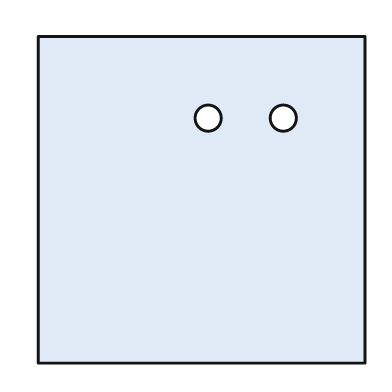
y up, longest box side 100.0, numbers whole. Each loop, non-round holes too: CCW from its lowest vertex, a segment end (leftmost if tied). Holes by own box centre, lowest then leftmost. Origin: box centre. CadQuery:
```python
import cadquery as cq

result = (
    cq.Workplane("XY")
    .moveTo(-50.0, -50.0)
    .lineTo(50.0, -50.0)
    .lineTo(50.0, 50.0)
    .lineTo(-50.0, 50.0)
    .close()
    .moveTo(2.0, 25.0)
    .circle(4.0)
    .moveTo(25.0, 25.0)
    .circle(4.0)
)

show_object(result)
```